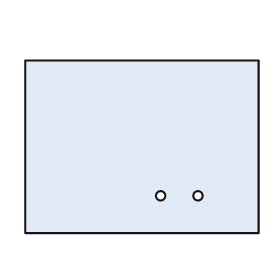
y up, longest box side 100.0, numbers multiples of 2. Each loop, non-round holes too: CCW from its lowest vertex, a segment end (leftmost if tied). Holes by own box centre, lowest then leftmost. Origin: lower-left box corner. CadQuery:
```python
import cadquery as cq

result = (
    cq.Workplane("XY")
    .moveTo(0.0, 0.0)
    .lineTo(100.0, 0.0)
    .lineTo(100.0, 74.0)
    .lineTo(0.0, 74.0)
    .close()
    .moveTo(58.0, 16.0)
    .circle(2.0)
    .moveTo(74.0, 16.0)
    .circle(2.0)
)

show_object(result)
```